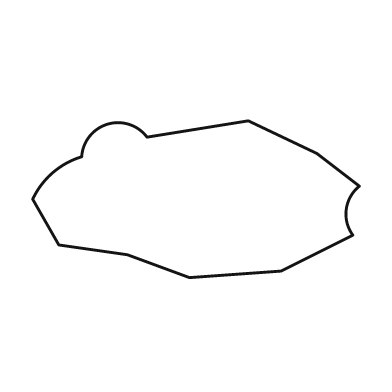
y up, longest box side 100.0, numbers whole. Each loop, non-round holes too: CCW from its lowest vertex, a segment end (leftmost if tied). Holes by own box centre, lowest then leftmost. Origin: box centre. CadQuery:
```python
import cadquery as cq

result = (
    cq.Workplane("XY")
    .moveTo(-2.0, -24.0)
    .lineTo(26.0, -22.0)
    .lineTo(48.0, -11.0)
    .threePointArc((46.0, -3.0), (50.0, 4.0))
    .lineTo(37.0, 14.0)
    .lineTo(16.0, 24.0)
    .lineTo(-15.0, 19.0)
    .threePointArc((-27.0, 23.0), (-35.0, 13.0))
    .threePointArc((-44.0, 8.0), (-50.0, 0.0))
    .lineTo(-42.0, -14.0)
    .lineTo(-21.0, -17.0)
    .close()
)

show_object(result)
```